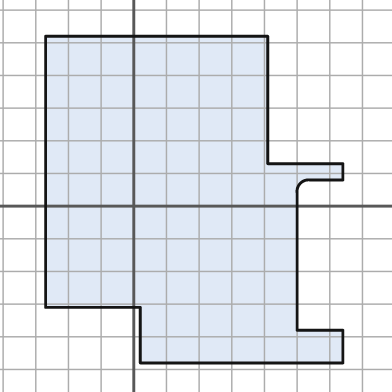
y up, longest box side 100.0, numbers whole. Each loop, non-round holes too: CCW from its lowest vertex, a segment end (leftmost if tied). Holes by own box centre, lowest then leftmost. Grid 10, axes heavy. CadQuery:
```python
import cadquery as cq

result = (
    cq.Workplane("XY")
    .moveTo(2.0, -48.0)
    .lineTo(64.0, -48.0)
    .lineTo(64.0, -38.0)
    .lineTo(50.0, -38.0)
    .lineTo(50.0, 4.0)
    .threePointArc((51.0, 7.0), (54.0, 8.0))
    .lineTo(64.0, 8.0)
    .lineTo(64.0, 13.0)
    .lineTo(41.0, 13.0)
    .lineTo(41.0, 52.0)
    .lineTo(-27.0, 52.0)
    .lineTo(-27.0, -31.0)
    .lineTo(2.0, -31.0)
    .close()
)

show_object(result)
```